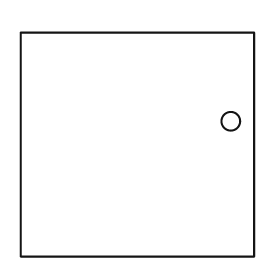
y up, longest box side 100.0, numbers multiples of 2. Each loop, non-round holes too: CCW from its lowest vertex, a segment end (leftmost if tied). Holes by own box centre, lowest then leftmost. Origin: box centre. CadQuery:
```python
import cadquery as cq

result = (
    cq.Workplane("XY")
    .moveTo(-50.0, -48.0)
    .lineTo(50.0, -48.0)
    .lineTo(50.0, 48.0)
    .lineTo(-50.0, 48.0)
    .close()
    .moveTo(40.0, 10.0)
    .circle(4.0)
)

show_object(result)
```